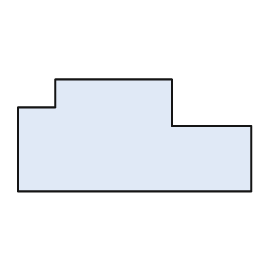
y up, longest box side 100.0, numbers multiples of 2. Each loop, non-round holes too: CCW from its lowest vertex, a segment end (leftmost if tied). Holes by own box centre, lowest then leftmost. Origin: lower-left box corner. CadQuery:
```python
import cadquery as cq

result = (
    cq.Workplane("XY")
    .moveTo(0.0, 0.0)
    .lineTo(100.0, 0.0)
    .lineTo(100.0, 28.0)
    .lineTo(66.0, 28.0)
    .lineTo(66.0, 48.0)
    .lineTo(16.0, 48.0)
    .lineTo(16.0, 36.0)
    .lineTo(0.0, 36.0)
    .close()
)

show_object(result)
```